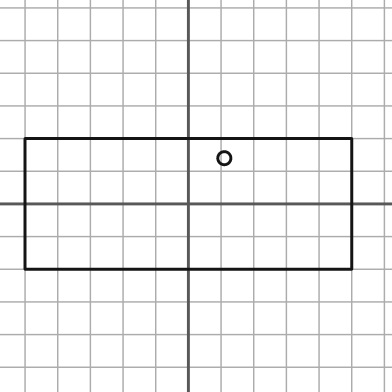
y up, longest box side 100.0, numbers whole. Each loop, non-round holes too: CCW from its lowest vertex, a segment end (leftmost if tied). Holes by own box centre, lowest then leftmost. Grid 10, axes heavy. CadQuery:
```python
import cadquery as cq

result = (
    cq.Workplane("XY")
    .moveTo(-50.0, -20.0)
    .lineTo(50.0, -20.0)
    .lineTo(50.0, 20.0)
    .lineTo(-50.0, 20.0)
    .close()
    .moveTo(11.0, 14.0)
    .circle(2.0)
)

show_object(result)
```